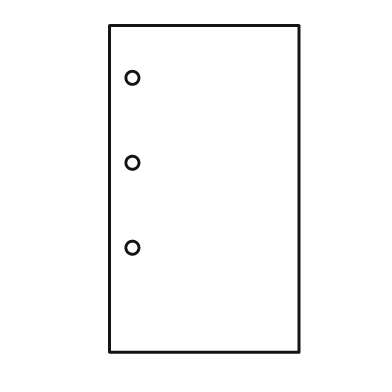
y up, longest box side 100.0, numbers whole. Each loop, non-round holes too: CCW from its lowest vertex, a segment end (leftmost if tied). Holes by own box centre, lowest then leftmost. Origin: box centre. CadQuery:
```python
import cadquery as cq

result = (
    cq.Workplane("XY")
    .moveTo(-29.0, -50.0)
    .lineTo(29.0, -50.0)
    .lineTo(29.0, 50.0)
    .lineTo(-29.0, 50.0)
    .close()
    .moveTo(-22.0, -18.0)
    .circle(2.0)
    .moveTo(-22.0, 8.0)
    .circle(2.0)
    .moveTo(-22.0, 34.0)
    .circle(2.0)
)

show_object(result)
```